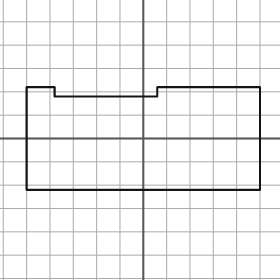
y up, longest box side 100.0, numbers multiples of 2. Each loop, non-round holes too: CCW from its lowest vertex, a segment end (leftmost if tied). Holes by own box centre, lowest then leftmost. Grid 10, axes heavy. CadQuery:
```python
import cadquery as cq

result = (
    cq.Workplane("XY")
    .moveTo(-50.0, -22.0)
    .lineTo(50.0, -22.0)
    .lineTo(50.0, 22.0)
    .lineTo(6.0, 22.0)
    .lineTo(6.0, 18.0)
    .lineTo(-38.0, 18.0)
    .lineTo(-38.0, 22.0)
    .lineTo(-50.0, 22.0)
    .close()
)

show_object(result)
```